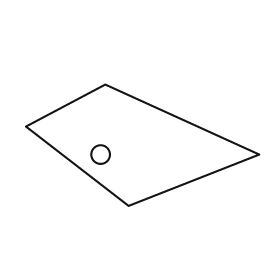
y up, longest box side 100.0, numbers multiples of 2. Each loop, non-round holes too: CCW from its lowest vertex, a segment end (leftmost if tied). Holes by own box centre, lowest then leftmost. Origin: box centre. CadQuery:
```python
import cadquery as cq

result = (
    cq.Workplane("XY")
    .moveTo(-6.0, -26.0)
    .lineTo(50.0, -4.0)
    .lineTo(-16.0, 26.0)
    .lineTo(-50.0, 8.0)
    .close()
    .moveTo(-18.0, -4.0)
    .circle(4.0)
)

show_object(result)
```